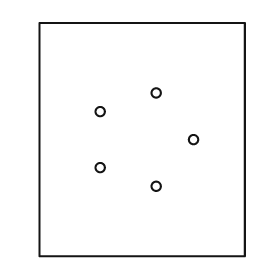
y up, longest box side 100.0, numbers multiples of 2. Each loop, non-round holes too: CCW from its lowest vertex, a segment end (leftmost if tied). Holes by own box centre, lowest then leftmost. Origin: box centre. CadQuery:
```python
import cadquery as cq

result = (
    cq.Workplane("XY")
    .moveTo(-44.0, -50.0)
    .lineTo(44.0, -50.0)
    .lineTo(44.0, 50.0)
    .lineTo(-44.0, 50.0)
    .close()
    .moveTo(6.0, -20.0)
    .circle(2.0)
    .moveTo(-18.0, -12.0)
    .circle(2.0)
    .moveTo(22.0, 0.0)
    .circle(2.0)
    .moveTo(-18.0, 12.0)
    .circle(2.0)
    .moveTo(6.0, 20.0)
    .circle(2.0)
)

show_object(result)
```